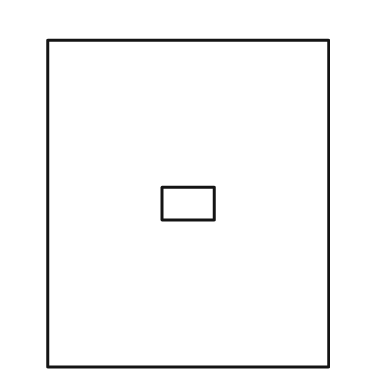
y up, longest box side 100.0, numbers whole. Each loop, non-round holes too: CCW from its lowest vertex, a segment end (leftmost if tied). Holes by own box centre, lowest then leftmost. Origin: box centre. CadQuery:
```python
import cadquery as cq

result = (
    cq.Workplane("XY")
    .moveTo(-43.0, -50.0)
    .lineTo(43.0, -50.0)
    .lineTo(43.0, 50.0)
    .lineTo(-43.0, 50.0)
    .close()
    .moveTo(-8.0, -5.0)
    .lineTo(8.0, -5.0)
    .lineTo(8.0, 5.0)
    .lineTo(-8.0, 5.0)
    .close()
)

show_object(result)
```